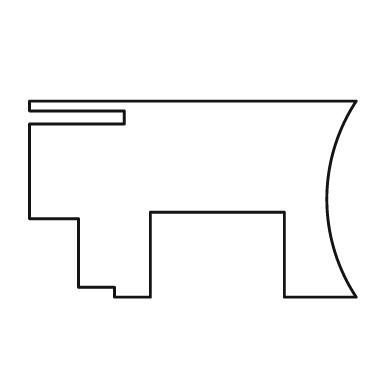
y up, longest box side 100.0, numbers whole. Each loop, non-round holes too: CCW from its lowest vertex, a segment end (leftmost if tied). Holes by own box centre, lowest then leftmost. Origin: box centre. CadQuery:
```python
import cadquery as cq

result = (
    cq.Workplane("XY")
    .moveTo(-24.0, -30.0)
    .lineTo(-13.0, -30.0)
    .lineTo(-13.0, -4.0)
    .lineTo(28.0, -4.0)
    .lineTo(28.0, -30.0)
    .lineTo(50.0, -30.0)
    .threePointArc((41.0, 0.0), (50.0, 30.0))
    .lineTo(-50.0, 30.0)
    .lineTo(-50.0, 27.0)
    .lineTo(-21.0, 27.0)
    .lineTo(-21.0, 23.0)
    .lineTo(-50.0, 23.0)
    .lineTo(-50.0, -6.0)
    .lineTo(-35.0, -6.0)
    .lineTo(-35.0, -27.0)
    .lineTo(-24.0, -27.0)
    .close()
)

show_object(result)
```